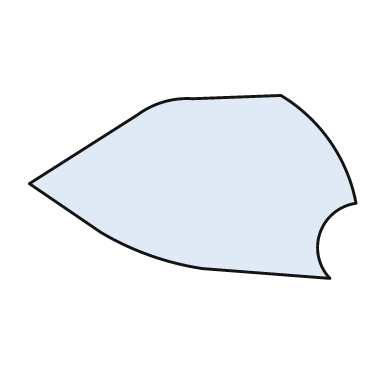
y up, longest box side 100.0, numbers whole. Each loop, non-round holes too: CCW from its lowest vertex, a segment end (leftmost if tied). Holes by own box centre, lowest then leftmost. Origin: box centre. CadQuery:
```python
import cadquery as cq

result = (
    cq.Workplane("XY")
    .moveTo(42.0, -28.0)
    .threePointArc((39.0, -14.0), (50.0, -5.0))
    .threePointArc((42.0, 14.0), (27.0, 28.0))
    .lineTo(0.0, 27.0)
    .threePointArc((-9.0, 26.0), (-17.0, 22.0))
    .lineTo(-50.0, 1.0)
    .lineTo(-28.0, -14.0)
    .threePointArc((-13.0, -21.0), (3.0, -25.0))
    .close()
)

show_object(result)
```